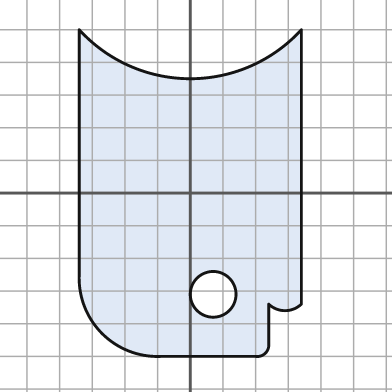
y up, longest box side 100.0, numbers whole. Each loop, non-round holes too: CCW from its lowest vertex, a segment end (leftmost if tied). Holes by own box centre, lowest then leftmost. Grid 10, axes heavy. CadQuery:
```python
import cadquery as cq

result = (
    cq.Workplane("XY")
    .moveTo(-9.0, -50.0)
    .lineTo(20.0, -50.0)
    .threePointArc((23.0, -49.0), (24.0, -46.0))
    .lineTo(24.0, -34.0)
    .threePointArc((29.0, -36.0), (34.0, -34.0))
    .lineTo(34.0, 50.0)
    .threePointArc((0.0, 35.0), (-34.0, 50.0))
    .lineTo(-34.0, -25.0)
    .threePointArc((-27.0, -43.0), (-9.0, -50.0))
    .close()
    .moveTo(7.0, -31.0)
    .circle(7.0)
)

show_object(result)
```